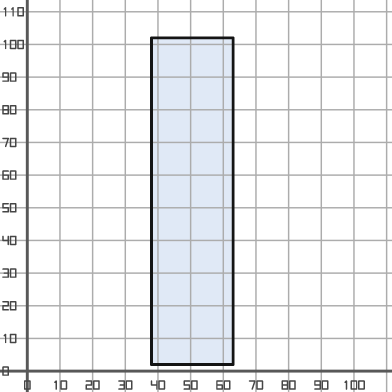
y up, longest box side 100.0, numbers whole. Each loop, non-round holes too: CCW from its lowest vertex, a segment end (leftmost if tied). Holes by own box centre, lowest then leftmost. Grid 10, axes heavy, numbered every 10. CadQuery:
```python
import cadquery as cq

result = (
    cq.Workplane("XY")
    .moveTo(38.0, 2.0)
    .lineTo(63.0, 2.0)
    .lineTo(63.0, 102.0)
    .lineTo(38.0, 102.0)
    .close()
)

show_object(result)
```